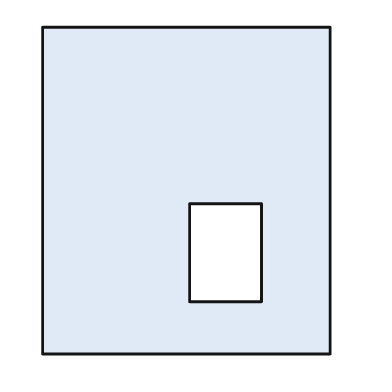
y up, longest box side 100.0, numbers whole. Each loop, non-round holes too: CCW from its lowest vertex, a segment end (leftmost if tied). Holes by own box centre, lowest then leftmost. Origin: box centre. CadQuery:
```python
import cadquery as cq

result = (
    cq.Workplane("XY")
    .moveTo(-44.0, -50.0)
    .lineTo(44.0, -50.0)
    .lineTo(44.0, 50.0)
    .lineTo(-44.0, 50.0)
    .close()
    .moveTo(1.0, -34.0)
    .lineTo(23.0, -34.0)
    .lineTo(23.0, -4.0)
    .lineTo(1.0, -4.0)
    .close()
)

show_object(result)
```